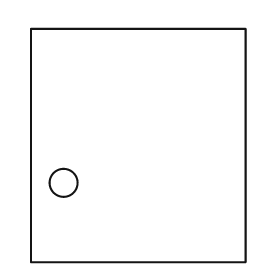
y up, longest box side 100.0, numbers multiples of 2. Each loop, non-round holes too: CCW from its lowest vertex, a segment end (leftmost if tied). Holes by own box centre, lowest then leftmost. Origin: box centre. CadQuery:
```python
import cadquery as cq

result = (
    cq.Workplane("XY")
    .moveTo(-46.0, -50.0)
    .lineTo(46.0, -50.0)
    .lineTo(46.0, 50.0)
    .lineTo(-46.0, 50.0)
    .close()
    .moveTo(-32.0, -16.0)
    .circle(6.0)
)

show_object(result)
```